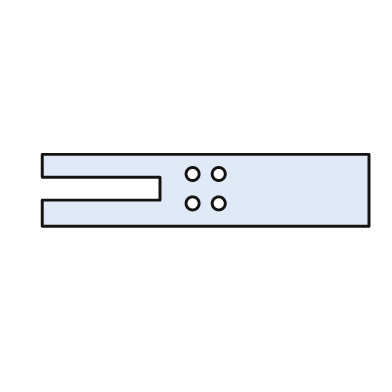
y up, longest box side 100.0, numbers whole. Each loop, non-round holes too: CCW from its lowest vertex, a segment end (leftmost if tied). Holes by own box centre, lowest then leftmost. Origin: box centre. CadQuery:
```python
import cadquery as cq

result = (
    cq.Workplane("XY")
    .moveTo(-50.0, -11.0)
    .lineTo(50.0, -11.0)
    .lineTo(50.0, 11.0)
    .lineTo(-50.0, 11.0)
    .lineTo(-50.0, 4.0)
    .lineTo(-14.0, 4.0)
    .lineTo(-14.0, -3.0)
    .lineTo(-50.0, -3.0)
    .close()
    .moveTo(-4.0, -4.0)
    .circle(2.0)
    .moveTo(4.0, -4.0)
    .circle(2.0)
    .moveTo(-4.0, 5.0)
    .circle(2.0)
    .moveTo(4.0, 5.0)
    .circle(2.0)
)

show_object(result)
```